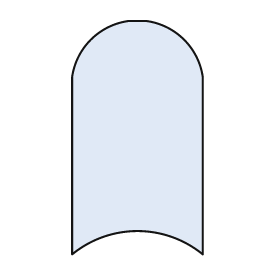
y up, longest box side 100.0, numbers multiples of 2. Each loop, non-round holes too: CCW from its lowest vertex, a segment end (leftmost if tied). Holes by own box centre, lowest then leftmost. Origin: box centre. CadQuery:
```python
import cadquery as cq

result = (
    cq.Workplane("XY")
    .moveTo(-28.0, -50.0)
    .threePointArc((0.0, -40.0), (28.0, -50.0))
    .lineTo(28.0, 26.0)
    .threePointArc((20.0, 42.0), (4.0, 50.0))
    .lineTo(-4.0, 50.0)
    .threePointArc((-20.0, 42.0), (-28.0, 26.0))
    .close()
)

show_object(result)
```